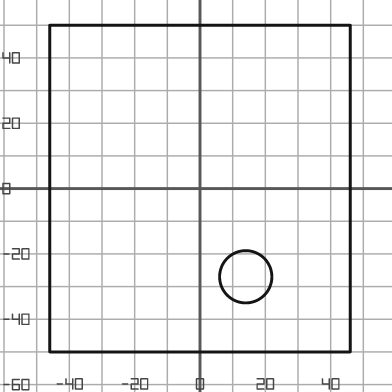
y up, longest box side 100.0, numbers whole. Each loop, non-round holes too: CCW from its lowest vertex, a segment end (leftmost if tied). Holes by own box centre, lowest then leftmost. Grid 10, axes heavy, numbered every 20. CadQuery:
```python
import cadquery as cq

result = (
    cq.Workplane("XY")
    .moveTo(-46.0, -50.0)
    .lineTo(46.0, -50.0)
    .lineTo(46.0, 50.0)
    .lineTo(-46.0, 50.0)
    .close()
    .moveTo(14.0, -27.0)
    .circle(8.0)
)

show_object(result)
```